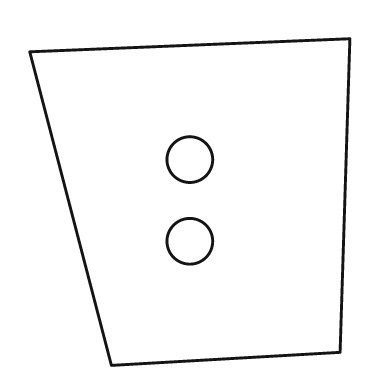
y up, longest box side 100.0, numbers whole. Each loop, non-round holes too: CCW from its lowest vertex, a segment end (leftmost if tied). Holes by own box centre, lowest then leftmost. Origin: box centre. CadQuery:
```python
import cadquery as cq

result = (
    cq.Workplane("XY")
    .moveTo(-24.0, -50.0)
    .lineTo(46.0, -46.0)
    .lineTo(49.0, 50.0)
    .lineTo(-49.0, 46.0)
    .close()
    .moveTo(0.0, -12.0)
    .circle(7.0)
    .moveTo(0.0, 13.0)
    .circle(7.0)
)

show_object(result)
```